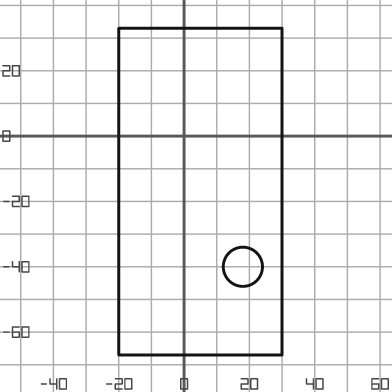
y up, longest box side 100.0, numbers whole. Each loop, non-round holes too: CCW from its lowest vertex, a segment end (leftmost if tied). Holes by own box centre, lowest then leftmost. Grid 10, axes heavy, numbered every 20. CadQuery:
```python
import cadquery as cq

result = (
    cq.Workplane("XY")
    .moveTo(-20.0, -67.0)
    .lineTo(30.0, -67.0)
    .lineTo(30.0, 33.0)
    .lineTo(-20.0, 33.0)
    .close()
    .moveTo(18.0, -40.0)
    .circle(6.0)
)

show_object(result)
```